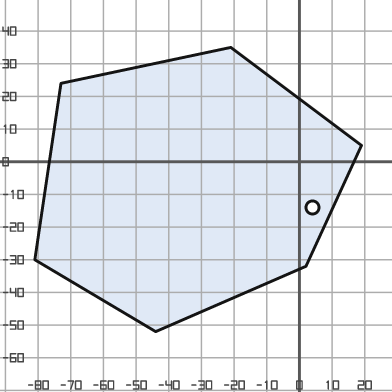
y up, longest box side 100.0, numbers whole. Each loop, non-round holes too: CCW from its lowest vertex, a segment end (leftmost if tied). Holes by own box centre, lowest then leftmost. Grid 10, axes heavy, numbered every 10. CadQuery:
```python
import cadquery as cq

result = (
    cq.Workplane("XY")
    .moveTo(-44.0, -52.0)
    .lineTo(2.0, -32.0)
    .lineTo(19.0, 5.0)
    .lineTo(-21.0, 35.0)
    .lineTo(-73.0, 24.0)
    .lineTo(-81.0, -30.0)
    .close()
    .moveTo(4.0, -14.0)
    .circle(2.0)
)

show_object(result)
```